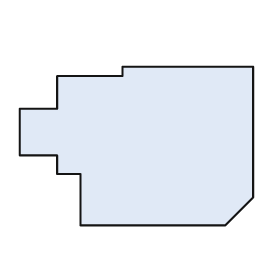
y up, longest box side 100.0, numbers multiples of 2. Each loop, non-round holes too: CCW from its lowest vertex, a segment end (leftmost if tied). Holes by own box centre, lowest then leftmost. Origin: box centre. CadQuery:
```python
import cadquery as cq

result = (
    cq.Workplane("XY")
    .moveTo(-24.0, -34.0)
    .lineTo(38.0, -34.0)
    .lineTo(50.0, -22.0)
    .lineTo(50.0, 34.0)
    .lineTo(-6.0, 34.0)
    .lineTo(-6.0, 30.0)
    .lineTo(-34.0, 30.0)
    .lineTo(-34.0, 16.0)
    .lineTo(-50.0, 16.0)
    .lineTo(-50.0, -4.0)
    .lineTo(-34.0, -4.0)
    .lineTo(-34.0, -12.0)
    .lineTo(-24.0, -12.0)
    .close()
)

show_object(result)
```